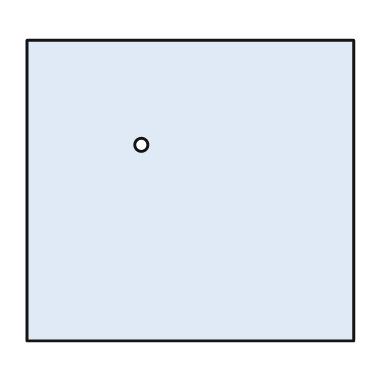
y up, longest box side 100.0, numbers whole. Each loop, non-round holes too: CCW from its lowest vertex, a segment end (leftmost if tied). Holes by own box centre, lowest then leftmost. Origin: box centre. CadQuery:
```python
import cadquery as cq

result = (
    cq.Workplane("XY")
    .moveTo(-50.0, -46.0)
    .lineTo(50.0, -46.0)
    .lineTo(50.0, 46.0)
    .lineTo(-50.0, 46.0)
    .close()
    .moveTo(-15.0, 14.0)
    .circle(2.0)
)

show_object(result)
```